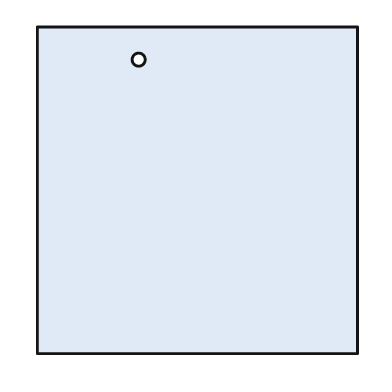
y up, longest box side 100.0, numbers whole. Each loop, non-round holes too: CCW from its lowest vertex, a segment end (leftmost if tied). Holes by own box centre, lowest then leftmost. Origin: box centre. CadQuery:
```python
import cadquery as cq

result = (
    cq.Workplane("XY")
    .moveTo(-49.0, -50.0)
    .lineTo(49.0, -50.0)
    .lineTo(49.0, 50.0)
    .lineTo(-49.0, 50.0)
    .close()
    .moveTo(-18.0, 40.0)
    .circle(2.0)
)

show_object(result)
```